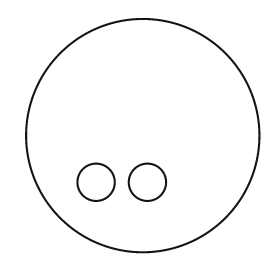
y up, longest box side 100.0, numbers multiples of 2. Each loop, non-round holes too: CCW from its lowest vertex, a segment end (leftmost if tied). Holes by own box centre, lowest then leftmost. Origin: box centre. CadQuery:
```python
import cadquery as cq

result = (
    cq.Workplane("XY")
    .moveTo(0.0, 0.0)
    .circle(50.0)
    .moveTo(-20.0, -20.0)
    .circle(8.0)
    .moveTo(2.0, -20.0)
    .circle(8.0)
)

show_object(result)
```